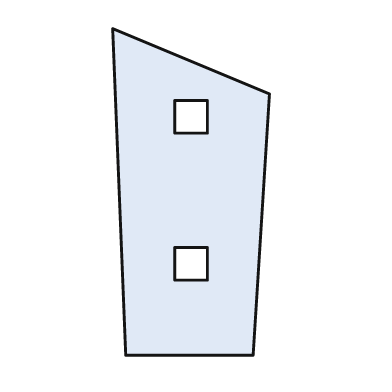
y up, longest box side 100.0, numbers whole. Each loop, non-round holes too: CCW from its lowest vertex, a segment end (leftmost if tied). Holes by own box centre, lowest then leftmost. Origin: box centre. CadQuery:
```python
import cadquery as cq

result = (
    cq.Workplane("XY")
    .moveTo(-20.0, -50.0)
    .lineTo(19.0, -50.0)
    .lineTo(24.0, 30.0)
    .lineTo(-24.0, 50.0)
    .close()
    .moveTo(-5.0, -27.0)
    .lineTo(5.0, -27.0)
    .lineTo(5.0, -17.0)
    .lineTo(-5.0, -17.0)
    .close()
    .moveTo(-5.0, 18.0)
    .lineTo(5.0, 18.0)
    .lineTo(5.0, 28.0)
    .lineTo(-5.0, 28.0)
    .close()
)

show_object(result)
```